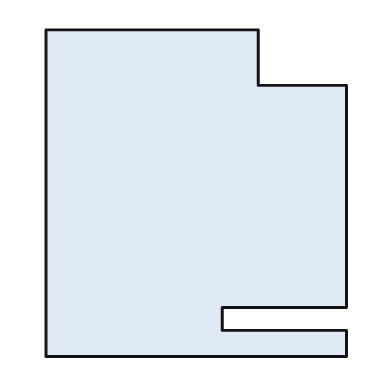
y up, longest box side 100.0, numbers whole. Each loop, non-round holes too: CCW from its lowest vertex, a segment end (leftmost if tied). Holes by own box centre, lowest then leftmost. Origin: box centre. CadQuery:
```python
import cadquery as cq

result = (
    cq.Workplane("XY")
    .moveTo(-46.0, -50.0)
    .lineTo(46.0, -50.0)
    .lineTo(46.0, -42.0)
    .lineTo(8.0, -42.0)
    .lineTo(8.0, -35.0)
    .lineTo(46.0, -35.0)
    .lineTo(46.0, 33.0)
    .lineTo(19.0, 33.0)
    .lineTo(19.0, 50.0)
    .lineTo(-46.0, 50.0)
    .close()
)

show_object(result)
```